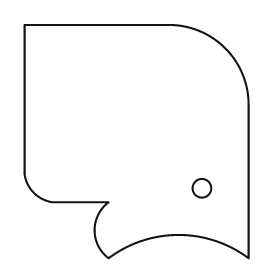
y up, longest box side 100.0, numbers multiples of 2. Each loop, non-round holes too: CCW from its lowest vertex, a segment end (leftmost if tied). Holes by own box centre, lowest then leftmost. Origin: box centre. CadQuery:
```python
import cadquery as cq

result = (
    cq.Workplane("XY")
    .moveTo(-12.0, -50.0)
    .threePointArc((18.0, -40.0), (48.0, -50.0))
    .lineTo(48.0, 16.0)
    .threePointArc((38.0, 40.0), (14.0, 50.0))
    .lineTo(-48.0, 50.0)
    .lineTo(-48.0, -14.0)
    .threePointArc((-44.0, -22.0), (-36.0, -26.0))
    .lineTo(-12.0, -26.0)
    .threePointArc((-18.0, -38.0), (-12.0, -50.0))
    .close()
    .moveTo(28.0, -20.0)
    .circle(4.0)
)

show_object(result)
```